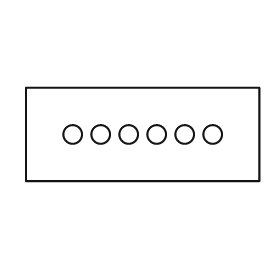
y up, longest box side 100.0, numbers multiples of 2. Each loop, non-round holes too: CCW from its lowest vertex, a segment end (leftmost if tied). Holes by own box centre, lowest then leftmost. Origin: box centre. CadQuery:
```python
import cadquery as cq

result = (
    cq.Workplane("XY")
    .moveTo(-50.0, -20.0)
    .lineTo(50.0, -20.0)
    .lineTo(50.0, 20.0)
    .lineTo(-50.0, 20.0)
    .close()
    .moveTo(-30.0, 0.0)
    .circle(4.0)
    .moveTo(-18.0, 0.0)
    .circle(4.0)
    .moveTo(-6.0, 0.0)
    .circle(4.0)
    .moveTo(6.0, 0.0)
    .circle(4.0)
    .moveTo(18.0, 0.0)
    .circle(4.0)
    .moveTo(30.0, 0.0)
    .circle(4.0)
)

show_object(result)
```